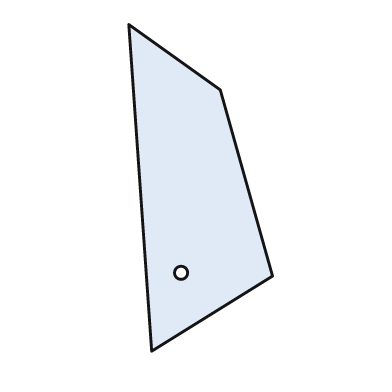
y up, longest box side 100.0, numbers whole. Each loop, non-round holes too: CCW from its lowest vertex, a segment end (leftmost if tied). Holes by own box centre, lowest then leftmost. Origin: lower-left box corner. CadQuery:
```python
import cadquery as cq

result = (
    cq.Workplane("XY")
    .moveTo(7.0, 0.0)
    .lineTo(44.0, 23.0)
    .lineTo(28.0, 80.0)
    .lineTo(0.0, 100.0)
    .close()
    .moveTo(16.0, 24.0)
    .circle(2.0)
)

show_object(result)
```